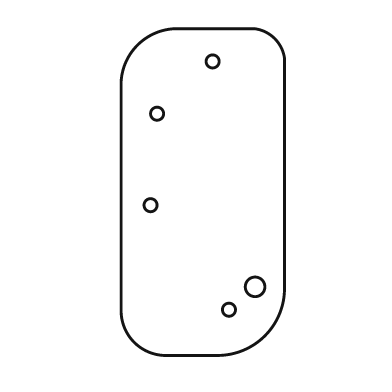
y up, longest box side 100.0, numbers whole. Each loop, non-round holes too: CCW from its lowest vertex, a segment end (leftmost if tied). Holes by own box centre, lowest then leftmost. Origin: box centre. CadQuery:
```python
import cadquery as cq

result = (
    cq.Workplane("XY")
    .moveTo(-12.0, -50.0)
    .lineTo(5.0, -50.0)
    .threePointArc((19.0, -44.0), (25.0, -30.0))
    .lineTo(25.0, 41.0)
    .threePointArc((22.0, 47.0), (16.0, 50.0))
    .lineTo(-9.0, 50.0)
    .threePointArc((-20.0, 45.0), (-25.0, 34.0))
    .lineTo(-25.0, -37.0)
    .threePointArc((-21.0, -46.0), (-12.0, -50.0))
    .close()
    .moveTo(8.0, -36.0)
    .circle(2.0)
    .moveTo(16.0, -29.0)
    .circle(3.0)
    .moveTo(-16.0, -4.0)
    .circle(2.0)
    .moveTo(-14.0, 24.0)
    .circle(2.0)
    .moveTo(3.0, 40.0)
    .circle(2.0)
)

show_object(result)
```